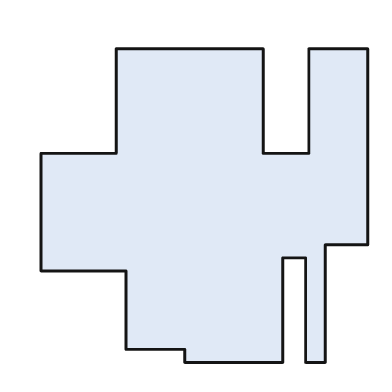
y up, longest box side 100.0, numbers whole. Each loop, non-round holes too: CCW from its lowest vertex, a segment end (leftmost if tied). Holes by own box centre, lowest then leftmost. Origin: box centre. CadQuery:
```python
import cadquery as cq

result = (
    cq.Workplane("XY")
    .moveTo(-6.0, -48.0)
    .lineTo(24.0, -48.0)
    .lineTo(24.0, -16.0)
    .lineTo(31.0, -16.0)
    .lineTo(31.0, -48.0)
    .lineTo(37.0, -48.0)
    .lineTo(37.0, -12.0)
    .lineTo(50.0, -12.0)
    .lineTo(50.0, 48.0)
    .lineTo(32.0, 48.0)
    .lineTo(32.0, 16.0)
    .lineTo(18.0, 16.0)
    .lineTo(18.0, 48.0)
    .lineTo(-27.0, 48.0)
    .lineTo(-27.0, 16.0)
    .lineTo(-50.0, 16.0)
    .lineTo(-50.0, -20.0)
    .lineTo(-24.0, -20.0)
    .lineTo(-24.0, -44.0)
    .lineTo(-6.0, -44.0)
    .close()
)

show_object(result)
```